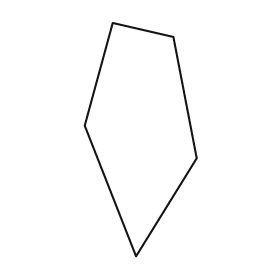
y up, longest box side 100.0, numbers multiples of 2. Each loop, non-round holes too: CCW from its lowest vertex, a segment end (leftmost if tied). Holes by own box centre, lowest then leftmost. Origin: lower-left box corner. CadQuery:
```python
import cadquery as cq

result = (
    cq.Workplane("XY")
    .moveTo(22.0, 0.0)
    .lineTo(48.0, 42.0)
    .lineTo(38.0, 94.0)
    .lineTo(12.0, 100.0)
    .lineTo(0.0, 56.0)
    .close()
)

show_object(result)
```